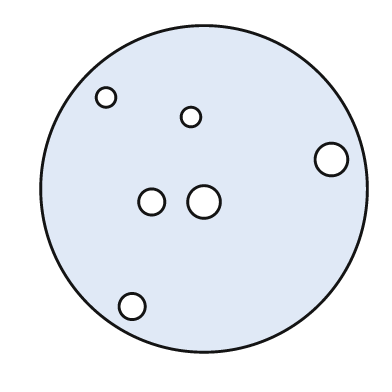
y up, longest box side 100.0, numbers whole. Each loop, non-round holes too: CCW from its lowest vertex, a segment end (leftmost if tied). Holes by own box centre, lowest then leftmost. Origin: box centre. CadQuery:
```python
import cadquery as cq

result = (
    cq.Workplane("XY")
    .moveTo(0.0, 0.0)
    .circle(50.0)
    .moveTo(-22.0, -36.0)
    .circle(4.0)
    .moveTo(-16.0, -4.0)
    .circle(4.0)
    .moveTo(0.0, -4.0)
    .circle(5.0)
    .moveTo(39.0, 9.0)
    .circle(5.0)
    .moveTo(-4.0, 22.0)
    .circle(3.0)
    .moveTo(-30.0, 28.0)
    .circle(3.0)
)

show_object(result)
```